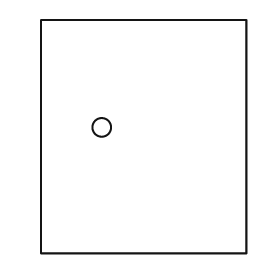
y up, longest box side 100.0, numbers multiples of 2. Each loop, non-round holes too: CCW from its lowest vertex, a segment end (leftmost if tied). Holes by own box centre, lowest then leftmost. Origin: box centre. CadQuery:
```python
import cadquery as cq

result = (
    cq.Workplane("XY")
    .moveTo(-44.0, -50.0)
    .lineTo(44.0, -50.0)
    .lineTo(44.0, 50.0)
    .lineTo(-44.0, 50.0)
    .close()
    .moveTo(-18.0, 4.0)
    .circle(4.0)
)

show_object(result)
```